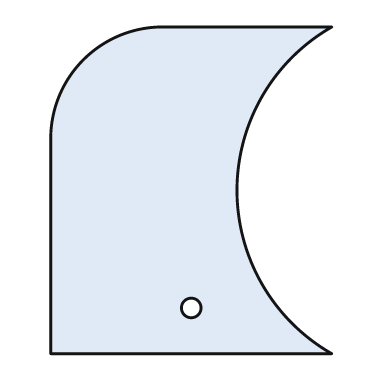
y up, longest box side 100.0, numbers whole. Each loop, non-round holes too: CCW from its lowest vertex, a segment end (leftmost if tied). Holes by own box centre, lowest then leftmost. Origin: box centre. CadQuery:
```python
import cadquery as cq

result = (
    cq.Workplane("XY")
    .moveTo(-43.0, -50.0)
    .lineTo(43.0, -50.0)
    .threePointArc((14.0, 0.0), (43.0, 50.0))
    .lineTo(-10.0, 50.0)
    .threePointArc((-33.0, 40.0), (-43.0, 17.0))
    .close()
    .moveTo(0.0, -36.0)
    .circle(3.0)
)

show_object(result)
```